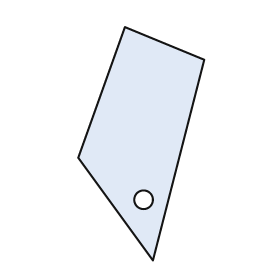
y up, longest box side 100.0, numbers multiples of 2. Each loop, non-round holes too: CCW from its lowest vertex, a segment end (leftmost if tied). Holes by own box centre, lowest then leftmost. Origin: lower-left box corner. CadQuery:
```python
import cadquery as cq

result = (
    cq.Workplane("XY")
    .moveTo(32.0, 0.0)
    .lineTo(54.0, 86.0)
    .lineTo(20.0, 100.0)
    .lineTo(0.0, 44.0)
    .close()
    .moveTo(28.0, 26.0)
    .circle(4.0)
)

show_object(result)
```